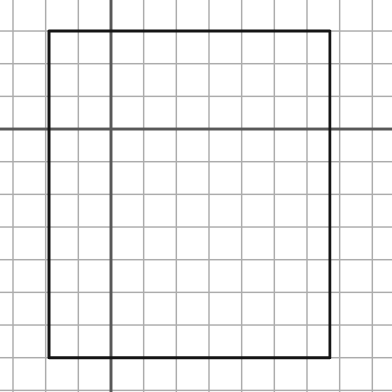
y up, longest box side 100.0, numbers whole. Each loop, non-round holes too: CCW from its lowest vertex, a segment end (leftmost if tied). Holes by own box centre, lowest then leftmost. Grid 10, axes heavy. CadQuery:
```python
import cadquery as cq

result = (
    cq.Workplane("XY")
    .moveTo(-19.0, -70.0)
    .lineTo(67.0, -70.0)
    .lineTo(67.0, 30.0)
    .lineTo(-19.0, 30.0)
    .close()
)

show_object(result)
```